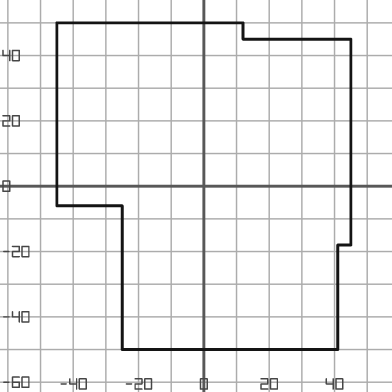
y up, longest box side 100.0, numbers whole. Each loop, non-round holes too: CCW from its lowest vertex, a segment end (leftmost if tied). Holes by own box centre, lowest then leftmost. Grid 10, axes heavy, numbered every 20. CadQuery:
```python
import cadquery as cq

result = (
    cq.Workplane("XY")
    .moveTo(-25.0, -50.0)
    .lineTo(41.0, -50.0)
    .lineTo(41.0, -18.0)
    .lineTo(45.0, -18.0)
    .lineTo(45.0, 45.0)
    .lineTo(12.0, 45.0)
    .lineTo(12.0, 50.0)
    .lineTo(-45.0, 50.0)
    .lineTo(-45.0, -6.0)
    .lineTo(-25.0, -6.0)
    .close()
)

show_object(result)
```